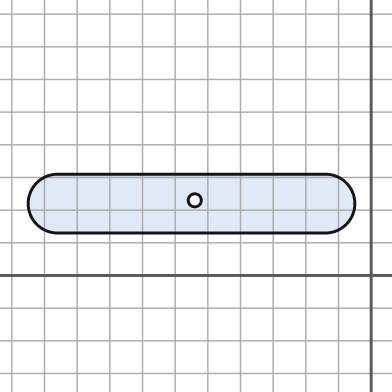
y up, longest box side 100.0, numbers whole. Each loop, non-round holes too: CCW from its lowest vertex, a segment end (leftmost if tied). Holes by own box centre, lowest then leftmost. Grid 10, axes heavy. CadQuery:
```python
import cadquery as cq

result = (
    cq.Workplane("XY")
    .moveTo(-96.0, 13.0)
    .lineTo(-14.0, 13.0)
    .threePointArc((-5.0, 22.0), (-14.0, 31.0))
    .lineTo(-96.0, 31.0)
    .threePointArc((-105.0, 22.0), (-96.0, 13.0))
    .close()
    .moveTo(-54.0, 23.0)
    .circle(2.0)
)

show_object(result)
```